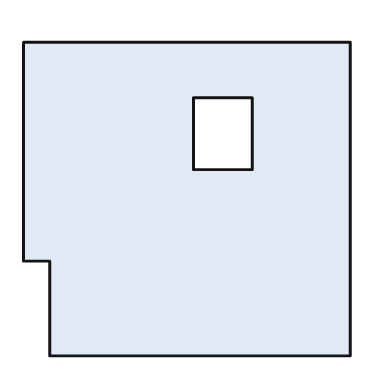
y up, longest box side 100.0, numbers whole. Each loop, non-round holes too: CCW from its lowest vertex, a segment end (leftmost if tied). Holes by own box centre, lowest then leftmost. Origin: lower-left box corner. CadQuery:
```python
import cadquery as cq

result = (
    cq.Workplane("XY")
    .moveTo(8.0, 0.0)
    .lineTo(100.0, 0.0)
    .lineTo(100.0, 96.0)
    .lineTo(0.0, 96.0)
    .lineTo(0.0, 29.0)
    .lineTo(8.0, 29.0)
    .close()
    .moveTo(52.0, 57.0)
    .lineTo(70.0, 57.0)
    .lineTo(70.0, 79.0)
    .lineTo(52.0, 79.0)
    .close()
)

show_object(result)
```